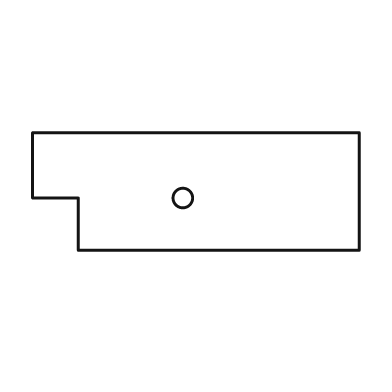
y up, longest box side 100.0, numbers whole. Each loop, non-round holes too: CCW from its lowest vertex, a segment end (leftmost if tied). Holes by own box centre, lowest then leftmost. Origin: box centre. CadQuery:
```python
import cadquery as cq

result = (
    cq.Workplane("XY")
    .moveTo(-36.0, -18.0)
    .lineTo(50.0, -18.0)
    .lineTo(50.0, 18.0)
    .lineTo(-50.0, 18.0)
    .lineTo(-50.0, -2.0)
    .lineTo(-36.0, -2.0)
    .close()
    .moveTo(-4.0, -2.0)
    .circle(3.0)
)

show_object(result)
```